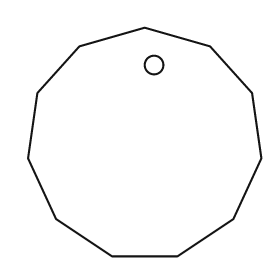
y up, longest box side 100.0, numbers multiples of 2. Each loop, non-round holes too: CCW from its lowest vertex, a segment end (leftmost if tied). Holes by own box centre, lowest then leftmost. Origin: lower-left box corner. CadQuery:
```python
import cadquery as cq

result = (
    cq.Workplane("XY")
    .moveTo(36.0, 0.0)
    .lineTo(64.0, 0.0)
    .lineTo(88.0, 16.0)
    .lineTo(100.0, 42.0)
    .lineTo(96.0, 70.0)
    .lineTo(78.0, 90.0)
    .lineTo(50.0, 98.0)
    .lineTo(22.0, 90.0)
    .lineTo(4.0, 70.0)
    .lineTo(0.0, 42.0)
    .lineTo(12.0, 16.0)
    .close()
    .moveTo(54.0, 82.0)
    .circle(4.0)
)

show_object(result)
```